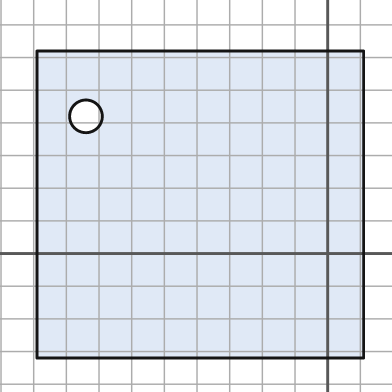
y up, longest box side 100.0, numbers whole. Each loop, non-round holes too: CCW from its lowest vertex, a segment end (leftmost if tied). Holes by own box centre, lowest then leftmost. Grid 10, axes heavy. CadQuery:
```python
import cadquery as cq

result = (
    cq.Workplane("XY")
    .moveTo(-89.0, -32.0)
    .lineTo(11.0, -32.0)
    .lineTo(11.0, 62.0)
    .lineTo(-89.0, 62.0)
    .close()
    .moveTo(-74.0, 42.0)
    .circle(5.0)
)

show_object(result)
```